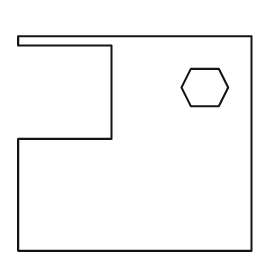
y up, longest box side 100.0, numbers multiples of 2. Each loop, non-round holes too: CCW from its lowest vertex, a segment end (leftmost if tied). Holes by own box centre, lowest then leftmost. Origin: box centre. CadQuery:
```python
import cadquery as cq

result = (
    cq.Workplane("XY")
    .moveTo(-50.0, -46.0)
    .lineTo(50.0, -46.0)
    .lineTo(50.0, 46.0)
    .lineTo(-50.0, 46.0)
    .lineTo(-50.0, 42.0)
    .lineTo(-10.0, 42.0)
    .lineTo(-10.0, 2.0)
    .lineTo(-50.0, 2.0)
    .close()
    .moveTo(24.0, 16.0)
    .lineTo(36.0, 16.0)
    .lineTo(40.0, 24.0)
    .lineTo(36.0, 32.0)
    .lineTo(24.0, 32.0)
    .lineTo(20.0, 24.0)
    .close()
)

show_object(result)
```